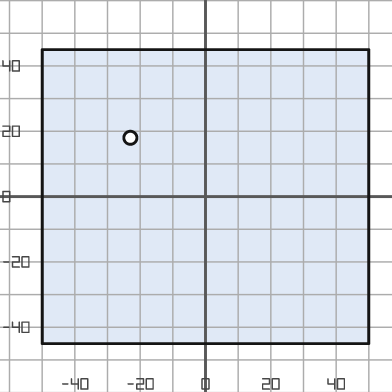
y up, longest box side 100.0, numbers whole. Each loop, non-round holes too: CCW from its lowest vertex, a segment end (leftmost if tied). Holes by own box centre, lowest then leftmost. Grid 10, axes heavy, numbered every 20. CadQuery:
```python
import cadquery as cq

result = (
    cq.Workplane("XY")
    .moveTo(-50.0, -45.0)
    .lineTo(50.0, -45.0)
    .lineTo(50.0, 45.0)
    .lineTo(-50.0, 45.0)
    .close()
    .moveTo(-23.0, 18.0)
    .circle(2.0)
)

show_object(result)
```